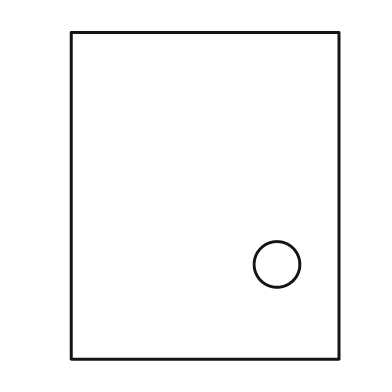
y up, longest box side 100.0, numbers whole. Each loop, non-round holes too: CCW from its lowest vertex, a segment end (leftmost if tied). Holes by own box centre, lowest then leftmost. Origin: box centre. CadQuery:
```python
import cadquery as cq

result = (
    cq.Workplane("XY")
    .moveTo(-41.0, -50.0)
    .lineTo(41.0, -50.0)
    .lineTo(41.0, 50.0)
    .lineTo(-41.0, 50.0)
    .close()
    .moveTo(22.0, -21.0)
    .circle(7.0)
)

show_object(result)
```